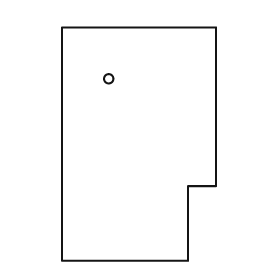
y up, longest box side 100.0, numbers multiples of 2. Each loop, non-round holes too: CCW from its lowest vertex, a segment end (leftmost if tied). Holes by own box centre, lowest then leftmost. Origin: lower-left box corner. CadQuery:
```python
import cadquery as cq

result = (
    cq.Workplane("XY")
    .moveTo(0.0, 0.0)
    .lineTo(54.0, 0.0)
    .lineTo(54.0, 32.0)
    .lineTo(66.0, 32.0)
    .lineTo(66.0, 100.0)
    .lineTo(0.0, 100.0)
    .close()
    .moveTo(20.0, 78.0)
    .circle(2.0)
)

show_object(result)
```